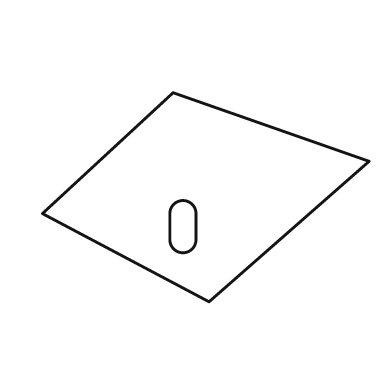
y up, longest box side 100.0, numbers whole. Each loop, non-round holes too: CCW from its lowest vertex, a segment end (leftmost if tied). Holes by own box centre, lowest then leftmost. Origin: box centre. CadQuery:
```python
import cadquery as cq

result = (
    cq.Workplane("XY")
    .moveTo(1.0, -32.0)
    .lineTo(50.0, 11.0)
    .lineTo(-10.0, 32.0)
    .lineTo(-50.0, -5.0)
    .close()
    .moveTo(-11.0, -13.0)
    .threePointArc((-7.0, -17.0), (-3.0, -13.0))
    .lineTo(-3.0, -5.0)
    .threePointArc((-7.0, -1.0), (-11.0, -5.0))
    .close()
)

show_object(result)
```